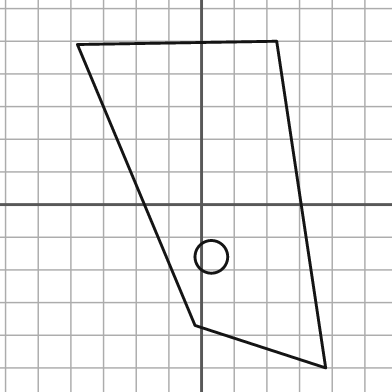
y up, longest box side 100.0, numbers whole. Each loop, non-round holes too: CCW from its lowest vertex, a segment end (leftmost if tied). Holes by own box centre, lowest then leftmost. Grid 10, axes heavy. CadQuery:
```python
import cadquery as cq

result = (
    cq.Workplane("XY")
    .moveTo(38.0, -50.0)
    .lineTo(23.0, 50.0)
    .lineTo(-38.0, 49.0)
    .lineTo(-2.0, -37.0)
    .close()
    .moveTo(3.0, -16.0)
    .circle(5.0)
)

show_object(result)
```